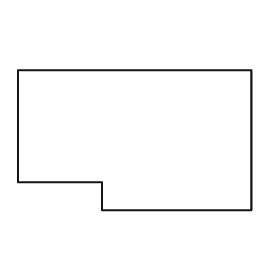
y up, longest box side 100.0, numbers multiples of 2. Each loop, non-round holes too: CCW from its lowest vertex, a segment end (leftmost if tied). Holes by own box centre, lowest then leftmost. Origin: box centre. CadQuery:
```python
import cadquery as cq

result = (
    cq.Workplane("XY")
    .moveTo(-14.0, -30.0)
    .lineTo(50.0, -30.0)
    .lineTo(50.0, 30.0)
    .lineTo(-50.0, 30.0)
    .lineTo(-50.0, -18.0)
    .lineTo(-14.0, -18.0)
    .close()
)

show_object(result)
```